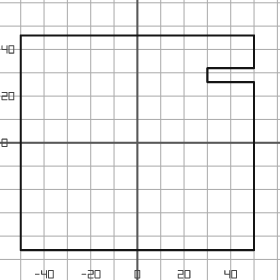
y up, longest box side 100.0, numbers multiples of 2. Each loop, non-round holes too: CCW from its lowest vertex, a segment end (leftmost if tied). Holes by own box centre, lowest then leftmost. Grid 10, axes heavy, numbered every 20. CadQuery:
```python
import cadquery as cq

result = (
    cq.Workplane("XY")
    .moveTo(-50.0, -46.0)
    .lineTo(50.0, -46.0)
    .lineTo(50.0, 26.0)
    .lineTo(30.0, 26.0)
    .lineTo(30.0, 32.0)
    .lineTo(50.0, 32.0)
    .lineTo(50.0, 46.0)
    .lineTo(-50.0, 46.0)
    .close()
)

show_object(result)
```